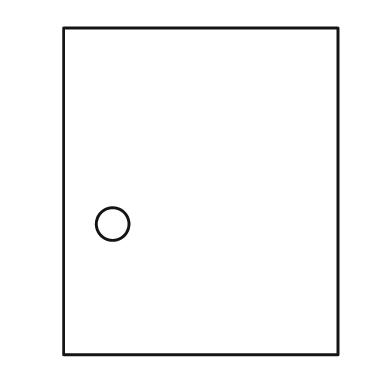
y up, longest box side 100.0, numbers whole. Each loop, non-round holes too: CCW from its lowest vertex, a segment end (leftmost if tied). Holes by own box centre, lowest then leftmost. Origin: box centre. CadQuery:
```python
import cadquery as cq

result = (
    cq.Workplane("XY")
    .moveTo(-42.0, -50.0)
    .lineTo(42.0, -50.0)
    .lineTo(42.0, 50.0)
    .lineTo(-42.0, 50.0)
    .close()
    .moveTo(-27.0, -10.0)
    .circle(5.0)
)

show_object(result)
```